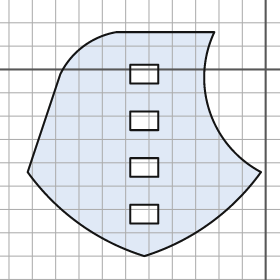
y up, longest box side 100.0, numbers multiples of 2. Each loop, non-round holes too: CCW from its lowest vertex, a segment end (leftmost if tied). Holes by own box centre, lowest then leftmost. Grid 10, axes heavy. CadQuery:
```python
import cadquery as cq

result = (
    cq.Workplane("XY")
    .moveTo(-52.0, -80.0)
    .threePointArc((-24.0, -66.0), (-2.0, -44.0))
    .threePointArc((-24.0, -18.0), (-22.0, 16.0))
    .lineTo(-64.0, 16.0)
    .threePointArc((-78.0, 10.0), (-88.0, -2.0))
    .lineTo(-102.0, -44.0)
    .threePointArc((-80.0, -66.0), (-52.0, -80.0))
    .close()
    .moveTo(-58.0, -66.0)
    .lineTo(-46.0, -66.0)
    .lineTo(-46.0, -58.0)
    .lineTo(-58.0, -58.0)
    .close()
    .moveTo(-58.0, -46.0)
    .lineTo(-46.0, -46.0)
    .lineTo(-46.0, -38.0)
    .lineTo(-58.0, -38.0)
    .close()
    .moveTo(-58.0, -26.0)
    .lineTo(-46.0, -26.0)
    .lineTo(-46.0, -18.0)
    .lineTo(-58.0, -18.0)
    .close()
    .moveTo(-58.0, -6.0)
    .lineTo(-46.0, -6.0)
    .lineTo(-46.0, 2.0)
    .lineTo(-58.0, 2.0)
    .close()
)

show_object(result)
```